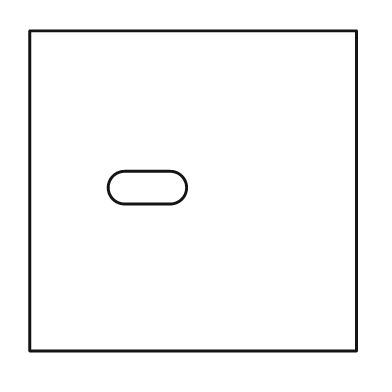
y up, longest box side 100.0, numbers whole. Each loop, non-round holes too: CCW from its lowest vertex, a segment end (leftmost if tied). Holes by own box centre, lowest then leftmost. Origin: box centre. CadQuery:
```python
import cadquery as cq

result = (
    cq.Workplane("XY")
    .moveTo(-50.0, -49.0)
    .lineTo(50.0, -49.0)
    .lineTo(50.0, 49.0)
    .lineTo(-50.0, 49.0)
    .close()
    .moveTo(-21.0, -4.0)
    .lineTo(-7.0, -4.0)
    .threePointArc((-2.0, 1.0), (-7.0, 6.0))
    .lineTo(-21.0, 6.0)
    .threePointArc((-26.0, 1.0), (-21.0, -4.0))
    .close()
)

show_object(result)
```